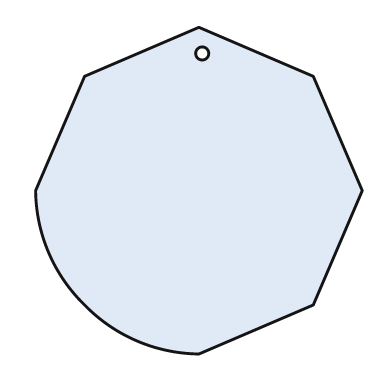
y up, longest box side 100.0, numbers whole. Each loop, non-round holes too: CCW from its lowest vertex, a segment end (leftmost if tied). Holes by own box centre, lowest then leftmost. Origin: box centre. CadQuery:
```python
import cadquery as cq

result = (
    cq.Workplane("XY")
    .moveTo(0.0, -50.0)
    .lineTo(35.0, -35.0)
    .lineTo(50.0, 0.0)
    .lineTo(35.0, 35.0)
    .lineTo(0.0, 50.0)
    .lineTo(-35.0, 35.0)
    .lineTo(-50.0, 0.0)
    .threePointArc((-46.0, -19.0), (-35.0, -35.0))
    .threePointArc((-19.0, -46.0), (0.0, -50.0))
    .close()
    .moveTo(1.0, 42.0)
    .circle(2.0)
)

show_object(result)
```